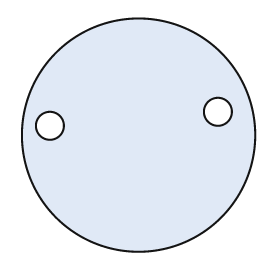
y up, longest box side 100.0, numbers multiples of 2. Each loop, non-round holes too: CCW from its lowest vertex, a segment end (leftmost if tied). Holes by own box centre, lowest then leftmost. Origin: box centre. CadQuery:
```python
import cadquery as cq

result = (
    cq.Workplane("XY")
    .moveTo(0.0, 0.0)
    .circle(50.0)
    .moveTo(-38.0, 4.0)
    .circle(6.0)
    .moveTo(34.0, 10.0)
    .circle(6.0)
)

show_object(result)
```